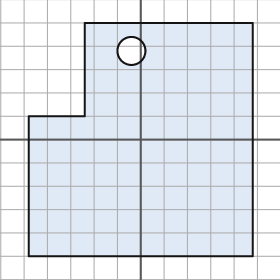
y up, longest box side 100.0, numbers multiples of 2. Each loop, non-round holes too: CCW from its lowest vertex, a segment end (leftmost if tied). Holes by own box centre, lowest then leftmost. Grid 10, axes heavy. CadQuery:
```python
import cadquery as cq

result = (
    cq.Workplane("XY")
    .moveTo(-48.0, -50.0)
    .lineTo(48.0, -50.0)
    .lineTo(48.0, 50.0)
    .lineTo(-24.0, 50.0)
    .lineTo(-24.0, 10.0)
    .lineTo(-48.0, 10.0)
    .close()
    .moveTo(-4.0, 38.0)
    .circle(6.0)
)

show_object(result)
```